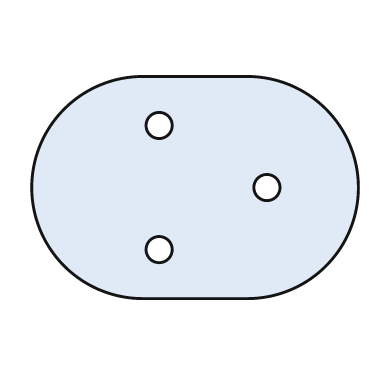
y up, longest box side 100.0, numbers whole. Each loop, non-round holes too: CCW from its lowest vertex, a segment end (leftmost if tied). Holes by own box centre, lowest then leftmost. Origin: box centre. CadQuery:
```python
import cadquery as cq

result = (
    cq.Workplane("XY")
    .moveTo(-16.0, -34.0)
    .lineTo(16.0, -34.0)
    .threePointArc((50.0, 0.0), (16.0, 34.0))
    .lineTo(-16.0, 34.0)
    .threePointArc((-50.0, 0.0), (-16.0, -34.0))
    .close()
    .moveTo(-11.0, -19.0)
    .circle(4.0)
    .moveTo(22.0, 0.0)
    .circle(4.0)
    .moveTo(-11.0, 19.0)
    .circle(4.0)
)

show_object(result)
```